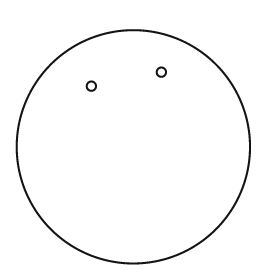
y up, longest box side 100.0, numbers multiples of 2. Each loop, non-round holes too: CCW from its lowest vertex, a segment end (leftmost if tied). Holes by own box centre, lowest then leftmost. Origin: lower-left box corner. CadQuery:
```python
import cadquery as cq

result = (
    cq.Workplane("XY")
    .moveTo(50.0, 50.0)
    .circle(50.0)
    .moveTo(32.0, 76.0)
    .circle(2.0)
    .moveTo(62.0, 82.0)
    .circle(2.0)
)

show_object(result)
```